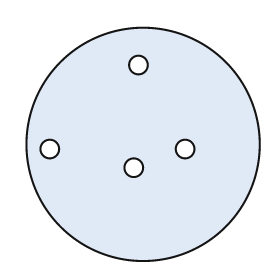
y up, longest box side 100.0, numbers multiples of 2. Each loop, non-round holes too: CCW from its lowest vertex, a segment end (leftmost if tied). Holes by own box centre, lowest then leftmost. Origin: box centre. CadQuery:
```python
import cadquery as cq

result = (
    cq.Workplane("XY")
    .moveTo(0.0, 0.0)
    .circle(50.0)
    .moveTo(-4.0, -10.0)
    .circle(4.0)
    .moveTo(-40.0, -2.0)
    .circle(4.0)
    .moveTo(18.0, -2.0)
    .circle(4.0)
    .moveTo(-2.0, 34.0)
    .circle(4.0)
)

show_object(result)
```